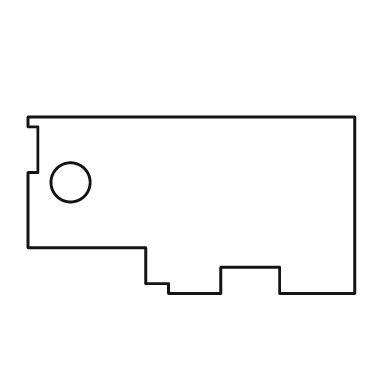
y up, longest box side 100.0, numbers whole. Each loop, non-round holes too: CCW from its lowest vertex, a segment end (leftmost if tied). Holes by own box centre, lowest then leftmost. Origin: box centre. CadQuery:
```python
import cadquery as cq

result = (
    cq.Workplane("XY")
    .moveTo(-7.0, -27.0)
    .lineTo(9.0, -27.0)
    .lineTo(9.0, -19.0)
    .lineTo(27.0, -19.0)
    .lineTo(27.0, -27.0)
    .lineTo(50.0, -27.0)
    .lineTo(50.0, 27.0)
    .lineTo(-50.0, 27.0)
    .lineTo(-50.0, 24.0)
    .lineTo(-47.0, 24.0)
    .lineTo(-47.0, 10.0)
    .lineTo(-50.0, 10.0)
    .lineTo(-50.0, -13.0)
    .lineTo(-14.0, -13.0)
    .lineTo(-14.0, -24.0)
    .lineTo(-7.0, -24.0)
    .close()
    .moveTo(-37.0, 7.0)
    .circle(6.0)
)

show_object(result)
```